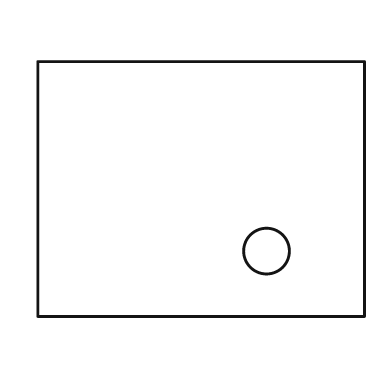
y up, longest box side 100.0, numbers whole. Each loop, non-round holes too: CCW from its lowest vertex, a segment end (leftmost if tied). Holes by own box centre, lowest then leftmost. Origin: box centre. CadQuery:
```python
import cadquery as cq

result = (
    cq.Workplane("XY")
    .moveTo(-50.0, -39.0)
    .lineTo(50.0, -39.0)
    .lineTo(50.0, 39.0)
    .lineTo(-50.0, 39.0)
    .close()
    .moveTo(20.0, -19.0)
    .circle(7.0)
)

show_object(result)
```